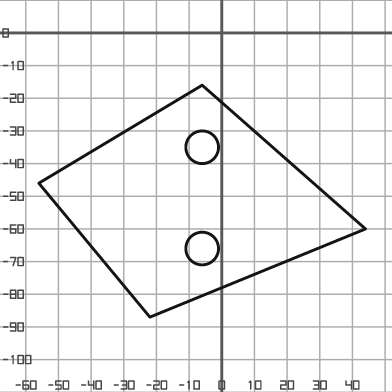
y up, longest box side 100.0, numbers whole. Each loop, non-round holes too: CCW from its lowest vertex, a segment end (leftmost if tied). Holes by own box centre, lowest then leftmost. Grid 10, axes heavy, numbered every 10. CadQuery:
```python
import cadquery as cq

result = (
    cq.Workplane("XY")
    .moveTo(-22.0, -87.0)
    .lineTo(44.0, -60.0)
    .lineTo(-6.0, -16.0)
    .lineTo(-56.0, -46.0)
    .close()
    .moveTo(-6.0, -66.0)
    .circle(5.0)
    .moveTo(-6.0, -35.0)
    .circle(5.0)
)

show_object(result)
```